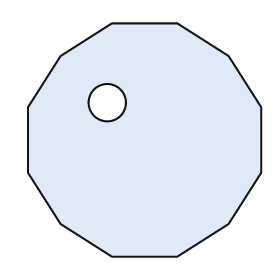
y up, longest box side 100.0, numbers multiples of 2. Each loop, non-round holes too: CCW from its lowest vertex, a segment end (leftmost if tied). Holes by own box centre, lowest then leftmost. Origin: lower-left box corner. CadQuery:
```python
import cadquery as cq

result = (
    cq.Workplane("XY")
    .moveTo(36.0, 0.0)
    .lineTo(64.0, 0.0)
    .lineTo(86.0, 14.0)
    .lineTo(100.0, 36.0)
    .lineTo(100.0, 64.0)
    .lineTo(86.0, 86.0)
    .lineTo(64.0, 100.0)
    .lineTo(36.0, 100.0)
    .lineTo(14.0, 86.0)
    .lineTo(0.0, 64.0)
    .lineTo(0.0, 36.0)
    .lineTo(14.0, 14.0)
    .close()
    .moveTo(34.0, 66.0)
    .circle(8.0)
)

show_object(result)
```